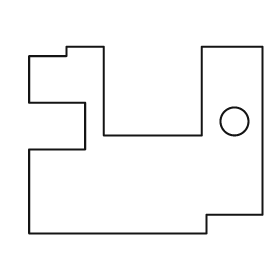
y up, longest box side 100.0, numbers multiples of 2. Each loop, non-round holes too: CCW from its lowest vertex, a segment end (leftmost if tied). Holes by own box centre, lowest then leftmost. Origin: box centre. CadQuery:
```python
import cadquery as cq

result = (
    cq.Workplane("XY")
    .moveTo(-50.0, -40.0)
    .lineTo(26.0, -40.0)
    .lineTo(26.0, -32.0)
    .lineTo(50.0, -32.0)
    .lineTo(50.0, 40.0)
    .lineTo(24.0, 40.0)
    .lineTo(24.0, 2.0)
    .lineTo(-18.0, 2.0)
    .lineTo(-18.0, 40.0)
    .lineTo(-34.0, 40.0)
    .lineTo(-34.0, 36.0)
    .lineTo(-50.0, 36.0)
    .lineTo(-50.0, 16.0)
    .lineTo(-26.0, 16.0)
    .lineTo(-26.0, -4.0)
    .lineTo(-50.0, -4.0)
    .close()
    .moveTo(38.0, 8.0)
    .circle(6.0)
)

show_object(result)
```